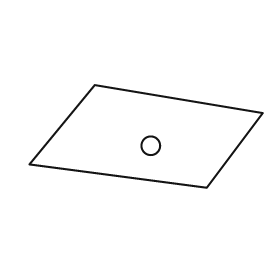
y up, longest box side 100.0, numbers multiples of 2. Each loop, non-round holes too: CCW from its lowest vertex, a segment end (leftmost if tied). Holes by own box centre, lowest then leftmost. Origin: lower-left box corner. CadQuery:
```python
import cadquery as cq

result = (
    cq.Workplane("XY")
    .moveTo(76.0, 0.0)
    .lineTo(100.0, 32.0)
    .lineTo(28.0, 44.0)
    .lineTo(0.0, 10.0)
    .close()
    .moveTo(52.0, 18.0)
    .circle(4.0)
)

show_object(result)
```